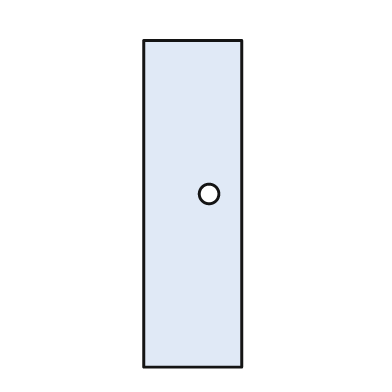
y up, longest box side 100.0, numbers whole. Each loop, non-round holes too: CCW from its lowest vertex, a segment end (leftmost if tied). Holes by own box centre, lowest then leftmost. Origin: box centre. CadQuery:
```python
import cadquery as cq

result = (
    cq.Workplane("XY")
    .moveTo(-15.0, -50.0)
    .lineTo(15.0, -50.0)
    .lineTo(15.0, 50.0)
    .lineTo(-15.0, 50.0)
    .close()
    .moveTo(5.0, 3.0)
    .circle(3.0)
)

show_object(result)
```